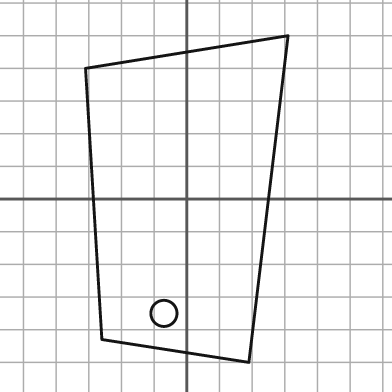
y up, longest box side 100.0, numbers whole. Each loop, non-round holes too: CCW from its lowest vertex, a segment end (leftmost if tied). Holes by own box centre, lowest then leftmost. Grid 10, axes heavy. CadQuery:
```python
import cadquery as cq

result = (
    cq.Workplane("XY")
    .moveTo(19.0, -50.0)
    .lineTo(31.0, 50.0)
    .lineTo(-31.0, 40.0)
    .lineTo(-26.0, -43.0)
    .close()
    .moveTo(-7.0, -35.0)
    .circle(4.0)
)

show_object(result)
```